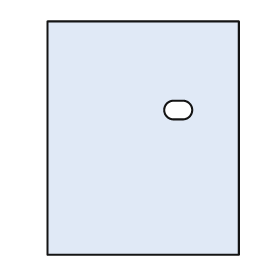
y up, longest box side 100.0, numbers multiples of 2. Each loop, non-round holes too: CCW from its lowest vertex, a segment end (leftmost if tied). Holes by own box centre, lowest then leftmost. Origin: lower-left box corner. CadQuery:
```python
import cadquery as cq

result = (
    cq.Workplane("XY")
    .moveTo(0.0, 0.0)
    .lineTo(82.0, 0.0)
    .lineTo(82.0, 100.0)
    .lineTo(0.0, 100.0)
    .close()
    .moveTo(54.0, 58.0)
    .lineTo(58.0, 58.0)
    .threePointArc((62.0, 62.0), (58.0, 66.0))
    .lineTo(54.0, 66.0)
    .threePointArc((50.0, 62.0), (54.0, 58.0))
    .close()
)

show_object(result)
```